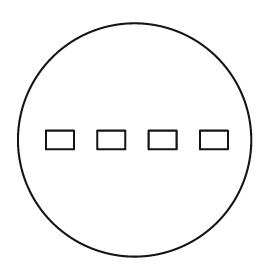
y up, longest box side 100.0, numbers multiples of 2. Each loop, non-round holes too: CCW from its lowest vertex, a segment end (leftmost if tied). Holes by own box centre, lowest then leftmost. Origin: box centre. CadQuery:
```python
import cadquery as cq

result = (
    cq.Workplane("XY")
    .moveTo(0.0, 0.0)
    .circle(50.0)
    .moveTo(-38.0, -4.0)
    .lineTo(-26.0, -4.0)
    .lineTo(-26.0, 4.0)
    .lineTo(-38.0, 4.0)
    .close()
    .moveTo(-16.0, -4.0)
    .lineTo(-4.0, -4.0)
    .lineTo(-4.0, 4.0)
    .lineTo(-16.0, 4.0)
    .close()
    .moveTo(6.0, -4.0)
    .lineTo(18.0, -4.0)
    .lineTo(18.0, 4.0)
    .lineTo(6.0, 4.0)
    .close()
    .moveTo(28.0, -4.0)
    .lineTo(40.0, -4.0)
    .lineTo(40.0, 4.0)
    .lineTo(28.0, 4.0)
    .close()
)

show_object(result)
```